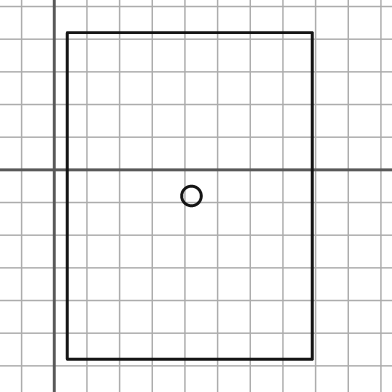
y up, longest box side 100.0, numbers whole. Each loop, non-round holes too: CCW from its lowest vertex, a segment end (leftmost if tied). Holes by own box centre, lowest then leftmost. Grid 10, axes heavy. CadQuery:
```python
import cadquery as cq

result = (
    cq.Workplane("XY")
    .moveTo(4.0, -58.0)
    .lineTo(79.0, -58.0)
    .lineTo(79.0, 42.0)
    .lineTo(4.0, 42.0)
    .close()
    .moveTo(42.0, -8.0)
    .circle(3.0)
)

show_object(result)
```